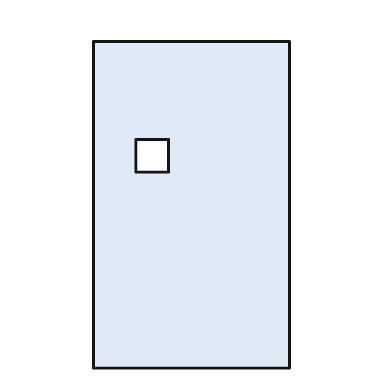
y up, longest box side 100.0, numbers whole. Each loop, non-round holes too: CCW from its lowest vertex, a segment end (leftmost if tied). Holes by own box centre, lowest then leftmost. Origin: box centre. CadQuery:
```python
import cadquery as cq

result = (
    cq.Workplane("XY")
    .moveTo(-30.0, -50.0)
    .lineTo(30.0, -50.0)
    .lineTo(30.0, 50.0)
    .lineTo(-30.0, 50.0)
    .close()
    .moveTo(-17.0, 10.0)
    .lineTo(-7.0, 10.0)
    .lineTo(-7.0, 20.0)
    .lineTo(-17.0, 20.0)
    .close()
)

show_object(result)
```